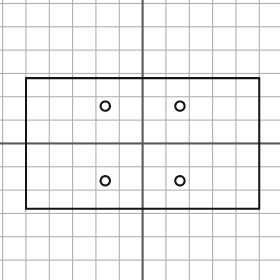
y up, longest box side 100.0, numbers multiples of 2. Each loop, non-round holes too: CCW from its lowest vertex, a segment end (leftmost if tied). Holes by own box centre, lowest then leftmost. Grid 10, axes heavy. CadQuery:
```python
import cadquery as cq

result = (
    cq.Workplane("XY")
    .moveTo(-50.0, -28.0)
    .lineTo(50.0, -28.0)
    .lineTo(50.0, 28.0)
    .lineTo(-50.0, 28.0)
    .close()
    .moveTo(-16.0, -16.0)
    .circle(2.0)
    .moveTo(16.0, -16.0)
    .circle(2.0)
    .moveTo(-16.0, 16.0)
    .circle(2.0)
    .moveTo(16.0, 16.0)
    .circle(2.0)
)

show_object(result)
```